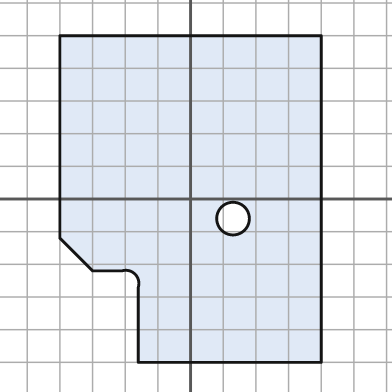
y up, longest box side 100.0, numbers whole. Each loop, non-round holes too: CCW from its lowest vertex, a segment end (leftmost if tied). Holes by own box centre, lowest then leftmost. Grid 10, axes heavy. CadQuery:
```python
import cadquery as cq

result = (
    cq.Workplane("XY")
    .moveTo(-16.0, -50.0)
    .lineTo(40.0, -50.0)
    .lineTo(40.0, 50.0)
    .lineTo(-40.0, 50.0)
    .lineTo(-40.0, -12.0)
    .lineTo(-30.0, -22.0)
    .lineTo(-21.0, -22.0)
    .threePointArc((-17.0, -23.0), (-16.0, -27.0))
    .close()
    .moveTo(13.0, -6.0)
    .circle(5.0)
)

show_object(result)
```